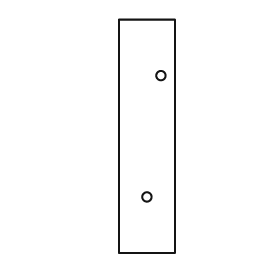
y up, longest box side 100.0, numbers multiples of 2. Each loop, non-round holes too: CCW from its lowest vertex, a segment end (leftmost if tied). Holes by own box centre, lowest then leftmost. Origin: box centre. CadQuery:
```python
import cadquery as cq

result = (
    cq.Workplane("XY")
    .moveTo(-12.0, -50.0)
    .lineTo(12.0, -50.0)
    .lineTo(12.0, 50.0)
    .lineTo(-12.0, 50.0)
    .close()
    .moveTo(0.0, -26.0)
    .circle(2.0)
    .moveTo(6.0, 26.0)
    .circle(2.0)
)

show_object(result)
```